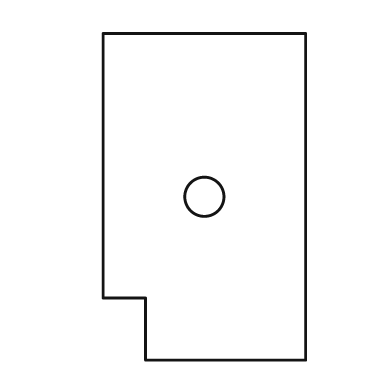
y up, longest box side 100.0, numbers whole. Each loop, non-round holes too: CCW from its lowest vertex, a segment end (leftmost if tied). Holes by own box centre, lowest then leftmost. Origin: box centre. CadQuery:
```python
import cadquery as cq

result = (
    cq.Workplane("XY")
    .moveTo(-18.0, -50.0)
    .lineTo(31.0, -50.0)
    .lineTo(31.0, 50.0)
    .lineTo(-31.0, 50.0)
    .lineTo(-31.0, -31.0)
    .lineTo(-18.0, -31.0)
    .close()
    .moveTo(0.0, 0.0)
    .circle(6.0)
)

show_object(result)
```